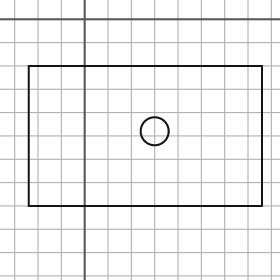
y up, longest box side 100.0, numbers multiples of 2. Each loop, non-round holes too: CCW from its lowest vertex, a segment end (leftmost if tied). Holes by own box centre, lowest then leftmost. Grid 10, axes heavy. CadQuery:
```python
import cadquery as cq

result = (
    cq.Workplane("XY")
    .moveTo(-24.0, -80.0)
    .lineTo(76.0, -80.0)
    .lineTo(76.0, -20.0)
    .lineTo(-24.0, -20.0)
    .close()
    .moveTo(30.0, -48.0)
    .circle(6.0)
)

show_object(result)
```